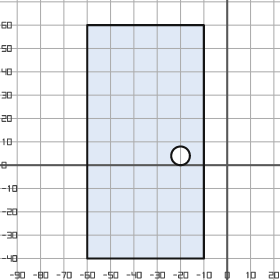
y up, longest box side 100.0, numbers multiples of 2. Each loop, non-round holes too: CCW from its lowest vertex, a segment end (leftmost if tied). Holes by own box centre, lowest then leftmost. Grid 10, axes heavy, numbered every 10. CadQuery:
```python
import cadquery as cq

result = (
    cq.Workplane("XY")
    .moveTo(-60.0, -40.0)
    .lineTo(-10.0, -40.0)
    .lineTo(-10.0, 60.0)
    .lineTo(-60.0, 60.0)
    .close()
    .moveTo(-20.0, 4.0)
    .circle(4.0)
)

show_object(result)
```